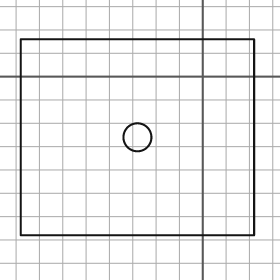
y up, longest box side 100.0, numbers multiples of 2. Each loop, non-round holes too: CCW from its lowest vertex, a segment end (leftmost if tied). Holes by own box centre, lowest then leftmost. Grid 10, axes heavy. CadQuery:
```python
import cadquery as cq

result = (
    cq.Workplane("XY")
    .moveTo(-78.0, -68.0)
    .lineTo(22.0, -68.0)
    .lineTo(22.0, 16.0)
    .lineTo(-78.0, 16.0)
    .close()
    .moveTo(-28.0, -26.0)
    .circle(6.0)
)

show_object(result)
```